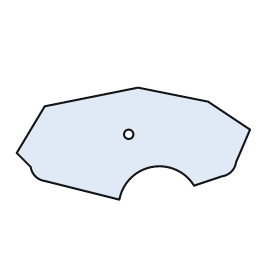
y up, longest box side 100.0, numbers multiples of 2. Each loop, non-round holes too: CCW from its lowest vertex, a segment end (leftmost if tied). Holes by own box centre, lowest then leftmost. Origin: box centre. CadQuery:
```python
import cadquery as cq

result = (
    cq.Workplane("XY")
    .moveTo(-6.0, -24.0)
    .threePointArc((8.0, -10.0), (26.0, -18.0))
    .lineTo(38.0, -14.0)
    .threePointArc((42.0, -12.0), (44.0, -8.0))
    .lineTo(50.0, 6.0)
    .lineTo(32.0, 18.0)
    .lineTo(2.0, 24.0)
    .lineTo(-38.0, 16.0)
    .lineTo(-50.0, -4.0)
    .lineTo(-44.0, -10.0)
    .threePointArc((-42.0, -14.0), (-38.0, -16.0))
    .close()
    .moveTo(-2.0, 4.0)
    .circle(2.0)
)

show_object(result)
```